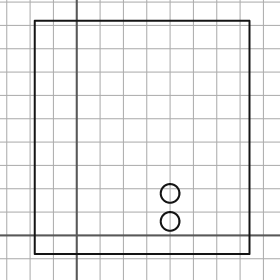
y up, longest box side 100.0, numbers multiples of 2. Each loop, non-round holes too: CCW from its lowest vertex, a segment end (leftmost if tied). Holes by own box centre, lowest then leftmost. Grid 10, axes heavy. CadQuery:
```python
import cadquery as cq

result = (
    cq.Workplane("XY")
    .moveTo(-18.0, -8.0)
    .lineTo(74.0, -8.0)
    .lineTo(74.0, 92.0)
    .lineTo(-18.0, 92.0)
    .close()
    .moveTo(40.0, 6.0)
    .circle(4.0)
    .moveTo(40.0, 18.0)
    .circle(4.0)
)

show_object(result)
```